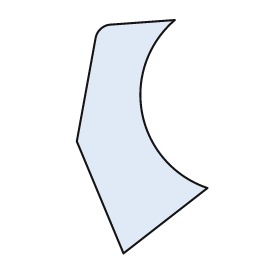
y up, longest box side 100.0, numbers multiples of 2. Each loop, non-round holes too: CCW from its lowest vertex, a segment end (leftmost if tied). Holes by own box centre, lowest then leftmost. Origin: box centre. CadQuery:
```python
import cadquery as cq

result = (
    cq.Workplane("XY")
    .moveTo(-8.0, -50.0)
    .lineTo(28.0, -22.0)
    .threePointArc((0.0, 10.0), (14.0, 50.0))
    .lineTo(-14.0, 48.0)
    .threePointArc((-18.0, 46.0), (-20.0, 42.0))
    .lineTo(-28.0, -2.0)
    .close()
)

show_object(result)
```